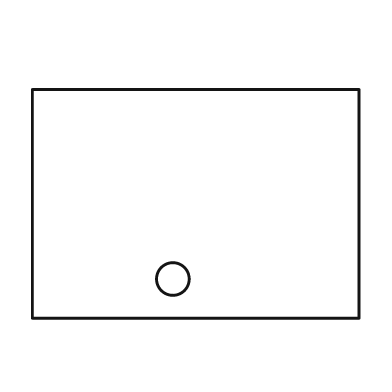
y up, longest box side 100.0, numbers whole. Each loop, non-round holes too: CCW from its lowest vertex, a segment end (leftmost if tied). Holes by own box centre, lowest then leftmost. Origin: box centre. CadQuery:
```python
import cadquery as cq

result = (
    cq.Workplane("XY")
    .moveTo(-50.0, -35.0)
    .lineTo(50.0, -35.0)
    .lineTo(50.0, 35.0)
    .lineTo(-50.0, 35.0)
    .close()
    .moveTo(-7.0, -23.0)
    .circle(5.0)
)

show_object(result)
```